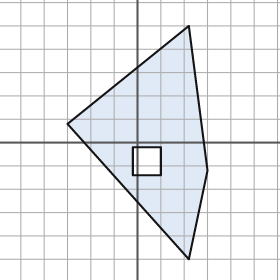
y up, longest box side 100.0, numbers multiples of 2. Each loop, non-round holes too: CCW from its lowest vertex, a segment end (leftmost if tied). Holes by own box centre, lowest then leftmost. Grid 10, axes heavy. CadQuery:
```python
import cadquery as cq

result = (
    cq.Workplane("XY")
    .moveTo(22.0, -50.0)
    .lineTo(30.0, -12.0)
    .lineTo(22.0, 50.0)
    .lineTo(-30.0, 8.0)
    .close()
    .moveTo(-2.0, -14.0)
    .lineTo(10.0, -14.0)
    .lineTo(10.0, -2.0)
    .lineTo(-2.0, -2.0)
    .close()
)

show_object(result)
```